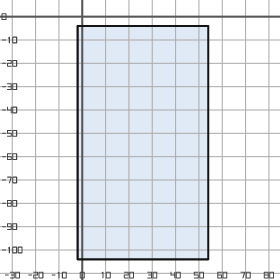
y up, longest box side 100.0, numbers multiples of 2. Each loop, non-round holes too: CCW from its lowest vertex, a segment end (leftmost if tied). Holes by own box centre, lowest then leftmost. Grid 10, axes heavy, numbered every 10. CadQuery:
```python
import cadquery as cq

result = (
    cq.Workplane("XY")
    .moveTo(-2.0, -104.0)
    .lineTo(54.0, -104.0)
    .lineTo(54.0, -4.0)
    .lineTo(-2.0, -4.0)
    .close()
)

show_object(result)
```